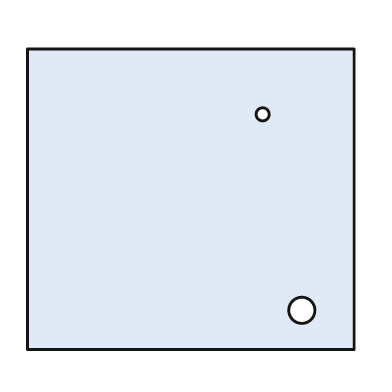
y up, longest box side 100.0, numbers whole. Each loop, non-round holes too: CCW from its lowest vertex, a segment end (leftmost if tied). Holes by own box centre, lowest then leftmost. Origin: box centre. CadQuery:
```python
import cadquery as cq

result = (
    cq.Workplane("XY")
    .moveTo(-50.0, -46.0)
    .lineTo(50.0, -46.0)
    .lineTo(50.0, 46.0)
    .lineTo(-50.0, 46.0)
    .close()
    .moveTo(34.0, -34.0)
    .circle(4.0)
    .moveTo(22.0, 26.0)
    .circle(2.0)
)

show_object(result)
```